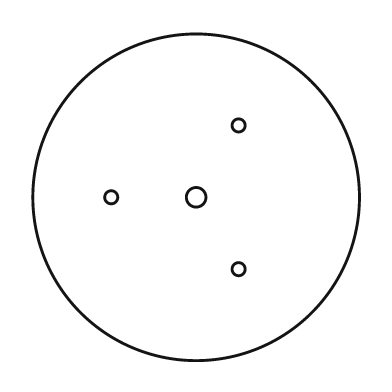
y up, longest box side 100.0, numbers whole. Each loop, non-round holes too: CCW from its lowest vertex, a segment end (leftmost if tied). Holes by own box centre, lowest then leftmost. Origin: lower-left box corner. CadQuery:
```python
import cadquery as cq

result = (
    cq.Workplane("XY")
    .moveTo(50.0, 50.0)
    .circle(50.0)
    .moveTo(63.0, 28.0)
    .circle(2.0)
    .moveTo(24.0, 50.0)
    .circle(2.0)
    .moveTo(50.0, 50.0)
    .circle(3.0)
    .moveTo(63.0, 72.0)
    .circle(2.0)
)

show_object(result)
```